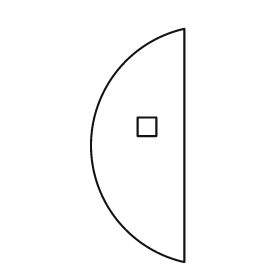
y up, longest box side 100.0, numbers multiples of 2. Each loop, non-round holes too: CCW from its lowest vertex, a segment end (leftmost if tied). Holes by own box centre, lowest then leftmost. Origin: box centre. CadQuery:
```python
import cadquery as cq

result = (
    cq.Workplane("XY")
    .moveTo(20.0, -50.0)
    .lineTo(20.0, 50.0)
    .threePointArc((-20.0, 0.0), (20.0, -50.0))
    .close()
    .moveTo(0.0, 4.0)
    .lineTo(8.0, 4.0)
    .lineTo(8.0, 12.0)
    .lineTo(0.0, 12.0)
    .close()
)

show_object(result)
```